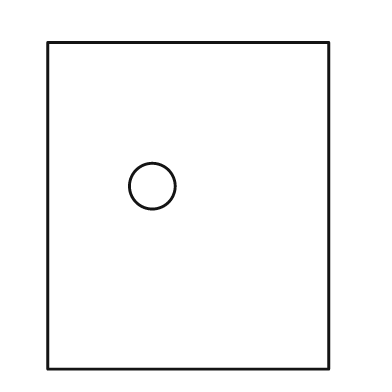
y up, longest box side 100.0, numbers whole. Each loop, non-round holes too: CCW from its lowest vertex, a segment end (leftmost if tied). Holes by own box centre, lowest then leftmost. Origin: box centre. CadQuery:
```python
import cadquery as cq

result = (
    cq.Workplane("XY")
    .moveTo(-43.0, -50.0)
    .lineTo(43.0, -50.0)
    .lineTo(43.0, 50.0)
    .lineTo(-43.0, 50.0)
    .close()
    .moveTo(-11.0, 6.0)
    .circle(7.0)
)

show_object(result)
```